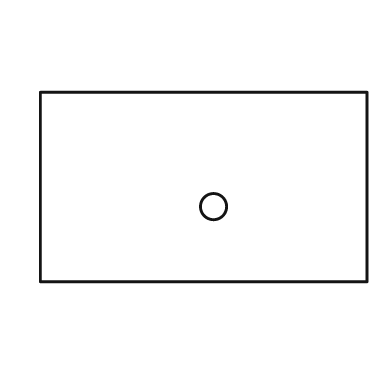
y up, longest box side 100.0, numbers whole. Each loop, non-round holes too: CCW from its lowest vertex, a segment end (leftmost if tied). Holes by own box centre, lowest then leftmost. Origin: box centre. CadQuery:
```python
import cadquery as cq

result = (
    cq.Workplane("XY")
    .moveTo(-50.0, -29.0)
    .lineTo(50.0, -29.0)
    .lineTo(50.0, 29.0)
    .lineTo(-50.0, 29.0)
    .close()
    .moveTo(3.0, -6.0)
    .circle(4.0)
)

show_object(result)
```